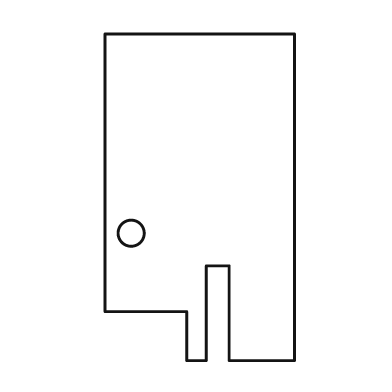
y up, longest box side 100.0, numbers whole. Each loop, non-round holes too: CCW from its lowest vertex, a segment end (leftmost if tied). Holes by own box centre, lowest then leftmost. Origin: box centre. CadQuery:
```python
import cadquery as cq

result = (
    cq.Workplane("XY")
    .moveTo(-4.0, -50.0)
    .lineTo(2.0, -50.0)
    .lineTo(2.0, -21.0)
    .lineTo(9.0, -21.0)
    .lineTo(9.0, -50.0)
    .lineTo(29.0, -50.0)
    .lineTo(29.0, 50.0)
    .lineTo(-29.0, 50.0)
    .lineTo(-29.0, -35.0)
    .lineTo(-4.0, -35.0)
    .close()
    .moveTo(-21.0, -11.0)
    .circle(4.0)
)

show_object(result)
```